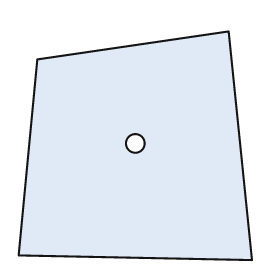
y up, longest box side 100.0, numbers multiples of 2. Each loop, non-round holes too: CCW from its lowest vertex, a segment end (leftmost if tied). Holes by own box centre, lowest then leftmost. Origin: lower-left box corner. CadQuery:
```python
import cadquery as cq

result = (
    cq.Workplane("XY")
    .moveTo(100.0, 0.0)
    .lineTo(90.0, 98.0)
    .lineTo(8.0, 86.0)
    .lineTo(0.0, 2.0)
    .close()
    .moveTo(50.0, 50.0)
    .circle(4.0)
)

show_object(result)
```